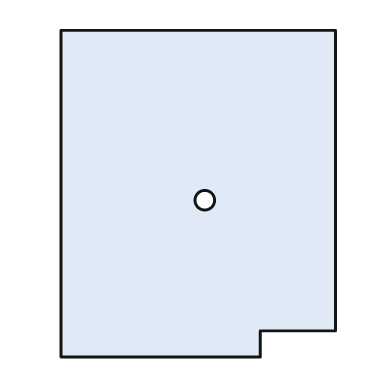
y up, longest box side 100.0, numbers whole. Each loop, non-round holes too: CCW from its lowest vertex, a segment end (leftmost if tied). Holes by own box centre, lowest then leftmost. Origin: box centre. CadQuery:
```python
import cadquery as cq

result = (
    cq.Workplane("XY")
    .moveTo(-42.0, -50.0)
    .lineTo(19.0, -50.0)
    .lineTo(19.0, -42.0)
    .lineTo(42.0, -42.0)
    .lineTo(42.0, 50.0)
    .lineTo(-42.0, 50.0)
    .close()
    .moveTo(2.0, -2.0)
    .circle(3.0)
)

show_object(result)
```